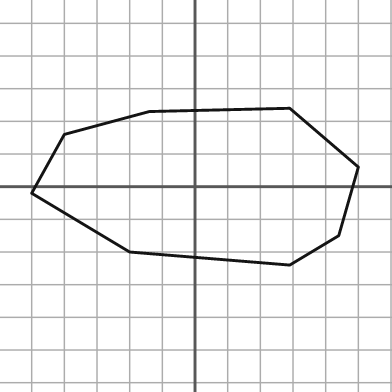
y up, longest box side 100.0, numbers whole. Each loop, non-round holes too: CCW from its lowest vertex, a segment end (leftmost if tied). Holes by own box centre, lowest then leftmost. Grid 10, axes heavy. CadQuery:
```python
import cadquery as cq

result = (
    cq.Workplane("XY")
    .moveTo(29.0, -24.0)
    .lineTo(44.0, -15.0)
    .lineTo(50.0, 6.0)
    .lineTo(29.0, 24.0)
    .lineTo(-14.0, 23.0)
    .lineTo(-40.0, 16.0)
    .lineTo(-50.0, -2.0)
    .lineTo(-20.0, -20.0)
    .close()
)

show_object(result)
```